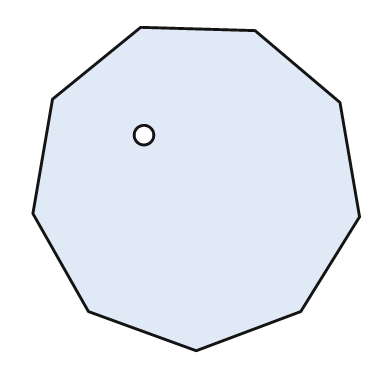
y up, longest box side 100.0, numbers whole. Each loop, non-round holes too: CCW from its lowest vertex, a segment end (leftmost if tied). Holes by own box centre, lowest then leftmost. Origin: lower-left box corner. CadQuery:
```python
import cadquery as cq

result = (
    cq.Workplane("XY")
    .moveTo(50.0, 0.0)
    .lineTo(82.0, 12.0)
    .lineTo(100.0, 41.0)
    .lineTo(94.0, 76.0)
    .lineTo(68.0, 98.0)
    .lineTo(33.0, 99.0)
    .lineTo(6.0, 77.0)
    .lineTo(0.0, 42.0)
    .lineTo(17.0, 12.0)
    .close()
    .moveTo(34.0, 66.0)
    .circle(3.0)
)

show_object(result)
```